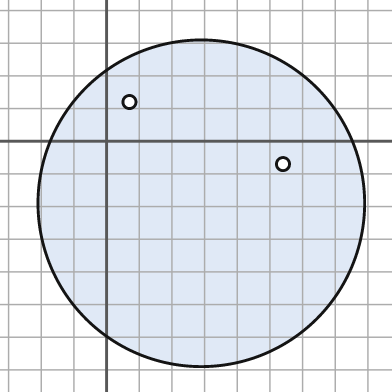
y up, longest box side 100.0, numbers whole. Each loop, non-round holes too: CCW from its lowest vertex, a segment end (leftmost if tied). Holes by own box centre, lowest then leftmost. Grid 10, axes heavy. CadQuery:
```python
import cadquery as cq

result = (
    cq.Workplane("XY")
    .moveTo(29.0, -19.0)
    .circle(50.0)
    .moveTo(54.0, -7.0)
    .circle(2.0)
    .moveTo(7.0, 12.0)
    .circle(2.0)
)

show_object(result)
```